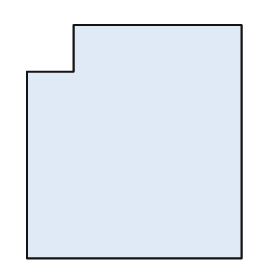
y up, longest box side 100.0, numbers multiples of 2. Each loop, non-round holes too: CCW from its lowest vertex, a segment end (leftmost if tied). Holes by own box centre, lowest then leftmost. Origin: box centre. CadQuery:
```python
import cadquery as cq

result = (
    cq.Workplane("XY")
    .moveTo(-46.0, -50.0)
    .lineTo(46.0, -50.0)
    .lineTo(46.0, 50.0)
    .lineTo(-26.0, 50.0)
    .lineTo(-26.0, 30.0)
    .lineTo(-46.0, 30.0)
    .close()
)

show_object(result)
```